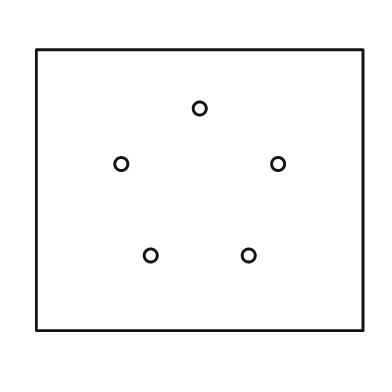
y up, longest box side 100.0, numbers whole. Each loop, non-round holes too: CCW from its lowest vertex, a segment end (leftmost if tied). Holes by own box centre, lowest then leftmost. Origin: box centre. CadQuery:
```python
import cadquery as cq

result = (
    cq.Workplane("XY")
    .moveTo(-50.0, -43.0)
    .lineTo(50.0, -43.0)
    .lineTo(50.0, 43.0)
    .lineTo(-50.0, 43.0)
    .close()
    .moveTo(-15.0, -20.0)
    .circle(2.0)
    .moveTo(15.0, -20.0)
    .circle(2.0)
    .moveTo(-24.0, 8.0)
    .circle(2.0)
    .moveTo(24.0, 8.0)
    .circle(2.0)
    .moveTo(0.0, 25.0)
    .circle(2.0)
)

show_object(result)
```